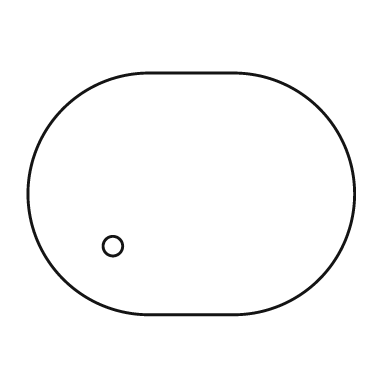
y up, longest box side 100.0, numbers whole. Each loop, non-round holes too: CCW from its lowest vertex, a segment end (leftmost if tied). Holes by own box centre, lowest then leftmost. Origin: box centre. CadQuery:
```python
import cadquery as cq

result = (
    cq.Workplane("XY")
    .moveTo(-13.0, -37.0)
    .lineTo(13.0, -37.0)
    .threePointArc((50.0, 0.0), (13.0, 37.0))
    .lineTo(-13.0, 37.0)
    .threePointArc((-50.0, 0.0), (-13.0, -37.0))
    .close()
    .moveTo(-24.0, -16.0)
    .circle(3.0)
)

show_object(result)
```